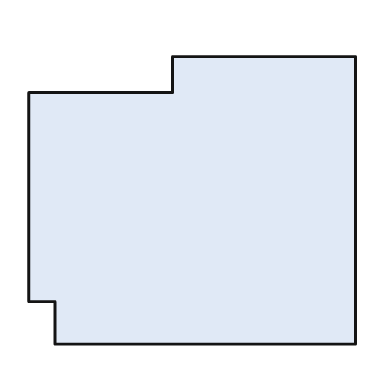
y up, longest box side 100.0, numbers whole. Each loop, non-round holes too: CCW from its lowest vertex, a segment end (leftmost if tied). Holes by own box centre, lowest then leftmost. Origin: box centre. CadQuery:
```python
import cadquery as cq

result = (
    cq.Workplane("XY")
    .moveTo(-42.0, -44.0)
    .lineTo(50.0, -44.0)
    .lineTo(50.0, 44.0)
    .lineTo(-6.0, 44.0)
    .lineTo(-6.0, 33.0)
    .lineTo(-50.0, 33.0)
    .lineTo(-50.0, -31.0)
    .lineTo(-42.0, -31.0)
    .close()
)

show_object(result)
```